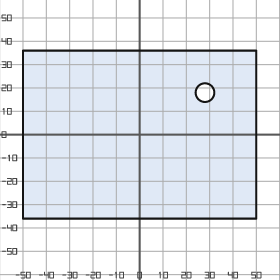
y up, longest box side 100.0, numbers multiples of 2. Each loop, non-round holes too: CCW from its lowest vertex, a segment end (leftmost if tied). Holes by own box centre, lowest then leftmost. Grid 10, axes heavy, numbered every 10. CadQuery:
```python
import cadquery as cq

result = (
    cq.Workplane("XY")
    .moveTo(-50.0, -36.0)
    .lineTo(50.0, -36.0)
    .lineTo(50.0, 36.0)
    .lineTo(-50.0, 36.0)
    .close()
    .moveTo(28.0, 18.0)
    .circle(4.0)
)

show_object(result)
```